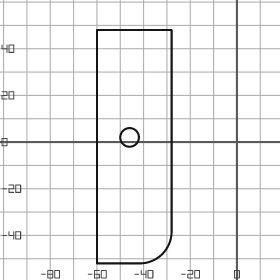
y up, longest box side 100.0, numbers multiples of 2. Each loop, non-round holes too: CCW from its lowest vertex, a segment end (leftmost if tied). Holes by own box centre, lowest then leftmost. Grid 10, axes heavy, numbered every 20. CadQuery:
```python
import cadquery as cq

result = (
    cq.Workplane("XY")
    .moveTo(-60.0, -52.0)
    .lineTo(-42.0, -52.0)
    .threePointArc((-32.0, -48.0), (-28.0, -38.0))
    .lineTo(-28.0, 48.0)
    .lineTo(-60.0, 48.0)
    .close()
    .moveTo(-46.0, 2.0)
    .circle(4.0)
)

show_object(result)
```